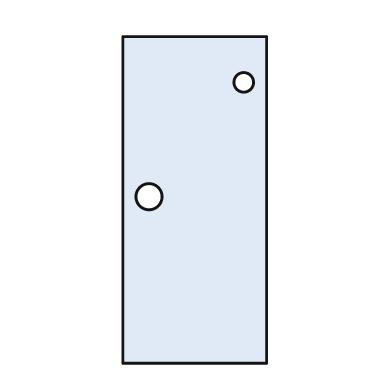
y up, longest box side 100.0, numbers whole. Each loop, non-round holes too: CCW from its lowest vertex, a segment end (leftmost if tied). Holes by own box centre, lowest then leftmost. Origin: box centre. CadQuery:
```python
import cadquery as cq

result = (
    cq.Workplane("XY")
    .moveTo(-22.0, -50.0)
    .lineTo(22.0, -50.0)
    .lineTo(22.0, 50.0)
    .lineTo(-22.0, 50.0)
    .close()
    .moveTo(-14.0, 1.0)
    .circle(4.0)
    .moveTo(15.0, 36.0)
    .circle(3.0)
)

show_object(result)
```